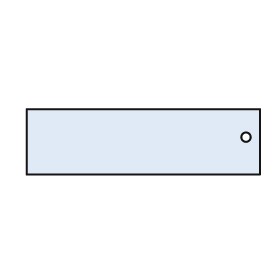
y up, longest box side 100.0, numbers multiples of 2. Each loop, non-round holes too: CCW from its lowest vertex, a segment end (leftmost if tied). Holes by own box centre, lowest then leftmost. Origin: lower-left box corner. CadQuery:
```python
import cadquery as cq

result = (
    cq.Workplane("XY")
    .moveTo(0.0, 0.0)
    .lineTo(100.0, 0.0)
    .lineTo(100.0, 28.0)
    .lineTo(0.0, 28.0)
    .close()
    .moveTo(94.0, 16.0)
    .circle(2.0)
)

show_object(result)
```